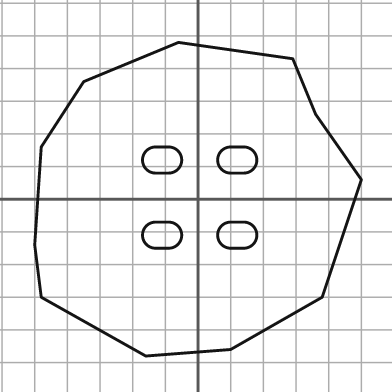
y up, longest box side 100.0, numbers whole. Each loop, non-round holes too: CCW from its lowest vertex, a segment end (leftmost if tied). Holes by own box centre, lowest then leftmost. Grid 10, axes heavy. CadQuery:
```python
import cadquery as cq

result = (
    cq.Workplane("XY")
    .moveTo(-16.0, -48.0)
    .lineTo(10.0, -46.0)
    .lineTo(38.0, -30.0)
    .lineTo(50.0, 6.0)
    .lineTo(36.0, 26.0)
    .lineTo(29.0, 43.0)
    .lineTo(-6.0, 48.0)
    .lineTo(-35.0, 36.0)
    .lineTo(-48.0, 16.0)
    .lineTo(-50.0, -14.0)
    .lineTo(-48.0, -30.0)
    .close()
    .moveTo(-13.0, -15.0)
    .lineTo(-9.0, -15.0)
    .threePointArc((-5.0, -11.0), (-9.0, -7.0))
    .lineTo(-13.0, -7.0)
    .threePointArc((-17.0, -11.0), (-13.0, -15.0))
    .close()
    .moveTo(10.0, -15.0)
    .lineTo(14.0, -15.0)
    .threePointArc((18.0, -11.0), (14.0, -7.0))
    .lineTo(10.0, -7.0)
    .threePointArc((6.0, -11.0), (10.0, -15.0))
    .close()
    .moveTo(-13.0, 8.0)
    .lineTo(-9.0, 8.0)
    .threePointArc((-5.0, 12.0), (-9.0, 16.0))
    .lineTo(-13.0, 16.0)
    .threePointArc((-17.0, 12.0), (-13.0, 8.0))
    .close()
    .moveTo(10.0, 8.0)
    .lineTo(14.0, 8.0)
    .threePointArc((18.0, 12.0), (14.0, 16.0))
    .lineTo(10.0, 16.0)
    .threePointArc((6.0, 12.0), (10.0, 8.0))
    .close()
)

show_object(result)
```